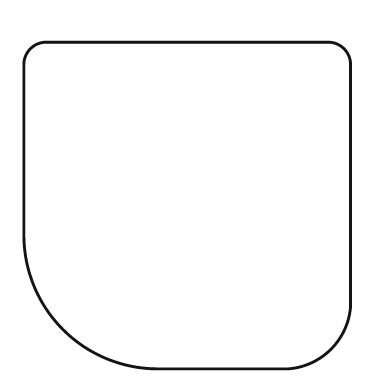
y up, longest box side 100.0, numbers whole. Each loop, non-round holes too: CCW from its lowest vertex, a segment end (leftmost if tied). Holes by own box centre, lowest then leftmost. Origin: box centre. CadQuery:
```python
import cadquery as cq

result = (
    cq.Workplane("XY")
    .moveTo(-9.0, -50.0)
    .lineTo(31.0, -50.0)
    .threePointArc((44.0, -44.0), (50.0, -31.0))
    .lineTo(50.0, 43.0)
    .threePointArc((48.0, 48.0), (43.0, 50.0))
    .lineTo(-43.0, 50.0)
    .threePointArc((-48.0, 48.0), (-50.0, 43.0))
    .lineTo(-50.0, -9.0)
    .threePointArc((-38.0, -38.0), (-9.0, -50.0))
    .close()
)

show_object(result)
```